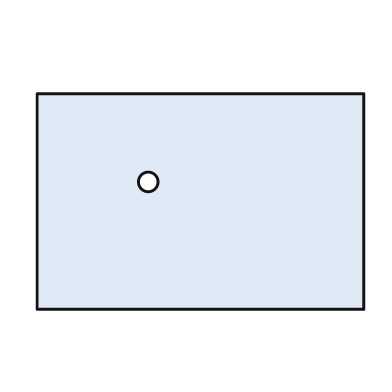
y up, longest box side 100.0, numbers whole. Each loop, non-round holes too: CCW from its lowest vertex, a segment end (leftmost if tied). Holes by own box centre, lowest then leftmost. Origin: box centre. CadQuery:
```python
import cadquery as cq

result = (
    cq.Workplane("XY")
    .moveTo(-50.0, -33.0)
    .lineTo(50.0, -33.0)
    .lineTo(50.0, 33.0)
    .lineTo(-50.0, 33.0)
    .close()
    .moveTo(-16.0, 6.0)
    .circle(3.0)
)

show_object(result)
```